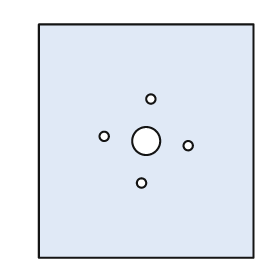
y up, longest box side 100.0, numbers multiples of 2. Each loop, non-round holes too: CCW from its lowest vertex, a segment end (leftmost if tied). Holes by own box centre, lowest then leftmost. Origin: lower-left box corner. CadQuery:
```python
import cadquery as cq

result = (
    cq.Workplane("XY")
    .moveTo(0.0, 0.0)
    .lineTo(92.0, 0.0)
    .lineTo(92.0, 100.0)
    .lineTo(0.0, 100.0)
    .close()
    .moveTo(44.0, 32.0)
    .circle(2.0)
    .moveTo(64.0, 48.0)
    .circle(2.0)
    .moveTo(46.0, 50.0)
    .circle(6.0)
    .moveTo(28.0, 52.0)
    .circle(2.0)
    .moveTo(48.0, 68.0)
    .circle(2.0)
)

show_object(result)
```